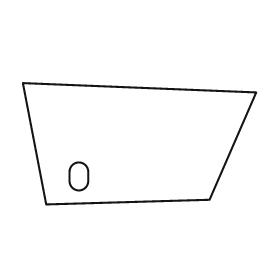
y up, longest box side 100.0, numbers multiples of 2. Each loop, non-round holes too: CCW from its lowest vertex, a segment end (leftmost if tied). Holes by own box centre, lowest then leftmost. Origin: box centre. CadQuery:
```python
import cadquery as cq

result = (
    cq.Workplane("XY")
    .moveTo(-40.0, -26.0)
    .lineTo(30.0, -24.0)
    .lineTo(50.0, 22.0)
    .lineTo(-50.0, 26.0)
    .close()
    .moveTo(-30.0, -16.0)
    .threePointArc((-26.0, -20.0), (-22.0, -16.0))
    .lineTo(-22.0, -12.0)
    .threePointArc((-26.0, -8.0), (-30.0, -12.0))
    .close()
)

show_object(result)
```